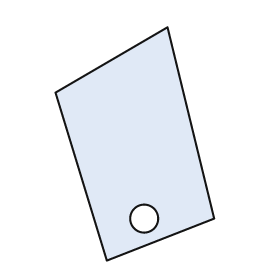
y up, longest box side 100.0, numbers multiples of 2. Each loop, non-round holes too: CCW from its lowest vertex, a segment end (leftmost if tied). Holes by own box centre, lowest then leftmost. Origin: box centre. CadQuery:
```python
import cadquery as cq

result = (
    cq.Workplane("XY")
    .moveTo(-12.0, -50.0)
    .lineTo(34.0, -32.0)
    .lineTo(14.0, 50.0)
    .lineTo(-34.0, 22.0)
    .close()
    .moveTo(4.0, -32.0)
    .circle(6.0)
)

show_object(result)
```